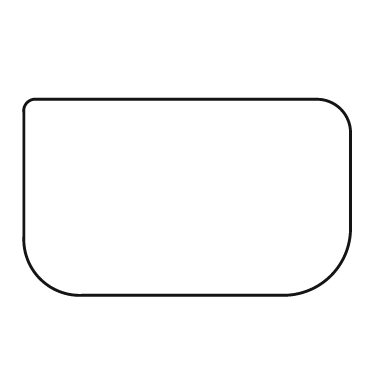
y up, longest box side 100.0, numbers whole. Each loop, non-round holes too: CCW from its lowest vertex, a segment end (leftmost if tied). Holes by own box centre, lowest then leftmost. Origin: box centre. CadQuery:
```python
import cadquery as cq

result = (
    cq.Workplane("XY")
    .moveTo(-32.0, -30.0)
    .lineTo(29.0, -30.0)
    .threePointArc((44.0, -24.0), (50.0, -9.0))
    .lineTo(50.0, 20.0)
    .threePointArc((47.0, 27.0), (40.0, 30.0))
    .lineTo(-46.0, 30.0)
    .threePointArc((-49.0, 29.0), (-50.0, 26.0))
    .lineTo(-50.0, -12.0)
    .threePointArc((-45.0, -25.0), (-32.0, -30.0))
    .close()
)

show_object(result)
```